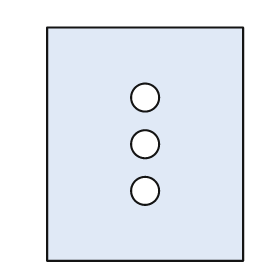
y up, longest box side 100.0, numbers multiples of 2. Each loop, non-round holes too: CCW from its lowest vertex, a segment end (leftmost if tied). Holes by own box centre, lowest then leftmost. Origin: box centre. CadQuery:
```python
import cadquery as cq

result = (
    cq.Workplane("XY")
    .moveTo(-42.0, -50.0)
    .lineTo(42.0, -50.0)
    .lineTo(42.0, 50.0)
    .lineTo(-42.0, 50.0)
    .close()
    .moveTo(0.0, -20.0)
    .circle(6.0)
    .moveTo(0.0, 0.0)
    .circle(6.0)
    .moveTo(0.0, 20.0)
    .circle(6.0)
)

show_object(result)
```